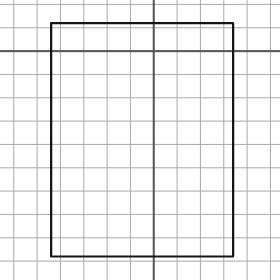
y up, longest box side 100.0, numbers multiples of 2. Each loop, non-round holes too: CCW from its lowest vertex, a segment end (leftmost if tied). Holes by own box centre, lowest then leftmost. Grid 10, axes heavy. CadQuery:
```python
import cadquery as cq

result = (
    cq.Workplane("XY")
    .moveTo(-44.0, -88.0)
    .lineTo(34.0, -88.0)
    .lineTo(34.0, 12.0)
    .lineTo(-44.0, 12.0)
    .close()
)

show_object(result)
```